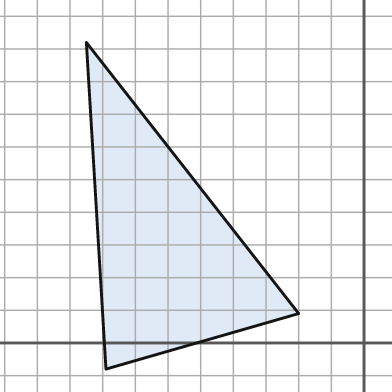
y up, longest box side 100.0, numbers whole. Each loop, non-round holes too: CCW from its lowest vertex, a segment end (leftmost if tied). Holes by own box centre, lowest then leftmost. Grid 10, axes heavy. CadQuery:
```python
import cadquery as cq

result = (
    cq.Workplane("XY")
    .moveTo(-79.0, -8.0)
    .lineTo(-20.0, 9.0)
    .lineTo(-85.0, 92.0)
    .close()
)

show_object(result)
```